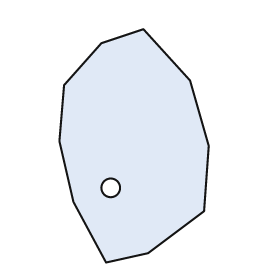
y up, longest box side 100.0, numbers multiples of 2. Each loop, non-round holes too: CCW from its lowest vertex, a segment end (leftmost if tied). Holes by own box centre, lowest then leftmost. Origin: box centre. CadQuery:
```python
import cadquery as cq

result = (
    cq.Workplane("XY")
    .moveTo(-12.0, -50.0)
    .lineTo(6.0, -46.0)
    .lineTo(30.0, -28.0)
    .lineTo(32.0, 0.0)
    .lineTo(24.0, 28.0)
    .lineTo(4.0, 50.0)
    .lineTo(-14.0, 44.0)
    .lineTo(-30.0, 26.0)
    .lineTo(-32.0, 2.0)
    .lineTo(-26.0, -24.0)
    .close()
    .moveTo(-10.0, -18.0)
    .circle(4.0)
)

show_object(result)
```